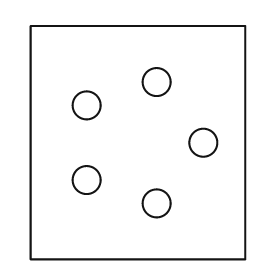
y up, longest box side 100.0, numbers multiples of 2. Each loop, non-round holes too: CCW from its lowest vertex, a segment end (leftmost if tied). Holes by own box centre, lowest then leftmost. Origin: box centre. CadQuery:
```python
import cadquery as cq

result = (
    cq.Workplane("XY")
    .moveTo(-46.0, -50.0)
    .lineTo(46.0, -50.0)
    .lineTo(46.0, 50.0)
    .lineTo(-46.0, 50.0)
    .close()
    .moveTo(8.0, -26.0)
    .circle(6.0)
    .moveTo(-22.0, -16.0)
    .circle(6.0)
    .moveTo(28.0, 0.0)
    .circle(6.0)
    .moveTo(-22.0, 16.0)
    .circle(6.0)
    .moveTo(8.0, 26.0)
    .circle(6.0)
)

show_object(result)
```